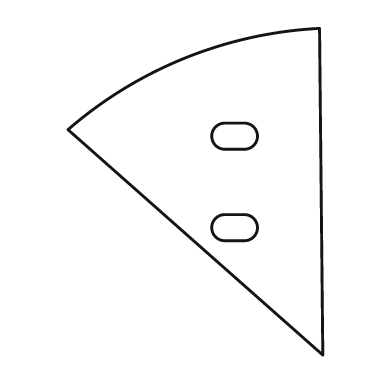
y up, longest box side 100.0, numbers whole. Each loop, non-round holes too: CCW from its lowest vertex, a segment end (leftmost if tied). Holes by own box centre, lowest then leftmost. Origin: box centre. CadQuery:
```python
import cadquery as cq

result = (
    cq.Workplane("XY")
    .moveTo(39.0, -50.0)
    .lineTo(38.0, 50.0)
    .threePointArc((-3.0, 41.0), (-39.0, 19.0))
    .close()
    .moveTo(9.0, -15.0)
    .lineTo(15.0, -15.0)
    .threePointArc((19.0, -11.0), (15.0, -7.0))
    .lineTo(9.0, -7.0)
    .threePointArc((5.0, -11.0), (9.0, -15.0))
    .close()
    .moveTo(9.0, 13.0)
    .lineTo(15.0, 13.0)
    .threePointArc((19.0, 17.0), (15.0, 21.0))
    .lineTo(9.0, 21.0)
    .threePointArc((5.0, 17.0), (9.0, 13.0))
    .close()
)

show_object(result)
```